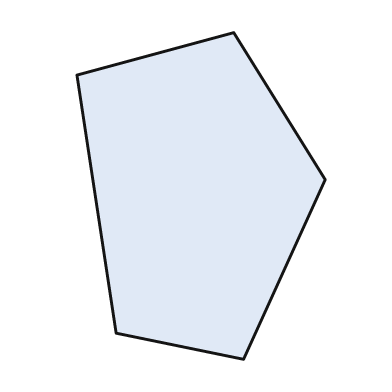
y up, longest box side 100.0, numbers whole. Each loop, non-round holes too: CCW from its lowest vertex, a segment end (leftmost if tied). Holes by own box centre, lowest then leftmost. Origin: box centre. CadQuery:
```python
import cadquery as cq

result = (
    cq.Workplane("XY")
    .moveTo(13.0, -50.0)
    .lineTo(38.0, 5.0)
    .lineTo(10.0, 50.0)
    .lineTo(-38.0, 37.0)
    .lineTo(-26.0, -42.0)
    .close()
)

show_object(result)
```